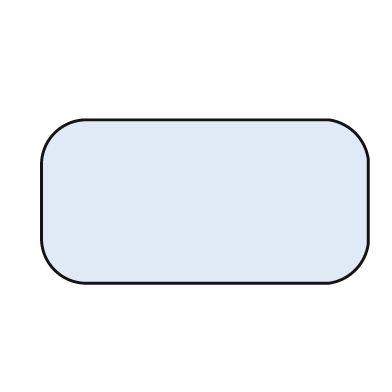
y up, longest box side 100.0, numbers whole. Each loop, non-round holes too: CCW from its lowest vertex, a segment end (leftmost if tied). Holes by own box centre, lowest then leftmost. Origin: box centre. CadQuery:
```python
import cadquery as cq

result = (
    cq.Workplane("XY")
    .moveTo(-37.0, -25.0)
    .lineTo(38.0, -25.0)
    .threePointArc((46.0, -21.0), (50.0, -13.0))
    .lineTo(50.0, 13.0)
    .threePointArc((46.0, 21.0), (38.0, 25.0))
    .lineTo(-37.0, 25.0)
    .threePointArc((-46.0, 21.0), (-50.0, 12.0))
    .lineTo(-50.0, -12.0)
    .threePointArc((-46.0, -21.0), (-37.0, -25.0))
    .close()
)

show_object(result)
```